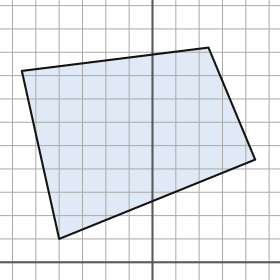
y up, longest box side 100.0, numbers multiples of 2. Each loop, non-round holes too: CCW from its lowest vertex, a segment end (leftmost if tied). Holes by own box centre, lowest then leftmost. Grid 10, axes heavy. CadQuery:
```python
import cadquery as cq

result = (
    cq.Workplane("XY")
    .moveTo(-40.0, 10.0)
    .lineTo(44.0, 44.0)
    .lineTo(24.0, 92.0)
    .lineTo(-56.0, 82.0)
    .close()
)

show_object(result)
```